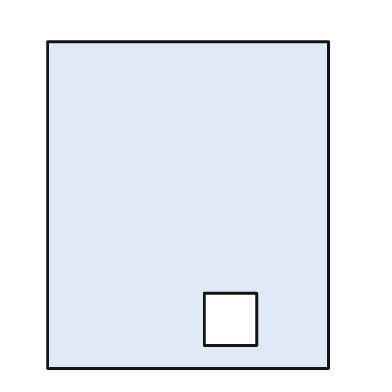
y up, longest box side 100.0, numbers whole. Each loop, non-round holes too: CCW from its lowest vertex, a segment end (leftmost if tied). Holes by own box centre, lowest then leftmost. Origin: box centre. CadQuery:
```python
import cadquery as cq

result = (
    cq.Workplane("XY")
    .moveTo(-43.0, -50.0)
    .lineTo(43.0, -50.0)
    .lineTo(43.0, 50.0)
    .lineTo(-43.0, 50.0)
    .close()
    .moveTo(5.0, -43.0)
    .lineTo(21.0, -43.0)
    .lineTo(21.0, -27.0)
    .lineTo(5.0, -27.0)
    .close()
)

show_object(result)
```